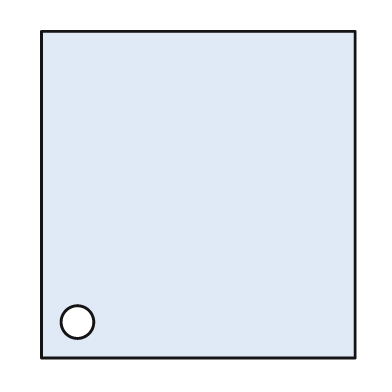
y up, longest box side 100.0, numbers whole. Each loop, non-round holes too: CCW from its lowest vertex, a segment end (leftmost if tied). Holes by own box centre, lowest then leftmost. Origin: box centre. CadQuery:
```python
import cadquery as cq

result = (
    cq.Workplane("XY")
    .moveTo(-48.0, -50.0)
    .lineTo(48.0, -50.0)
    .lineTo(48.0, 50.0)
    .lineTo(-48.0, 50.0)
    .close()
    .moveTo(-37.0, -39.0)
    .circle(5.0)
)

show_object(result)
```